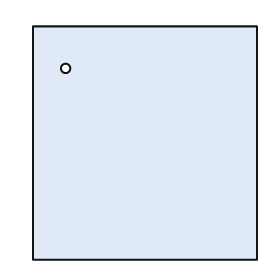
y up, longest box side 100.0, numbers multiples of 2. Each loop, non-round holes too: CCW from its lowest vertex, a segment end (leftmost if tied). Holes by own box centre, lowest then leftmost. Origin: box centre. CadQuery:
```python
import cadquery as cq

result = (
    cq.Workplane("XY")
    .moveTo(-48.0, -50.0)
    .lineTo(48.0, -50.0)
    .lineTo(48.0, 50.0)
    .lineTo(-48.0, 50.0)
    .close()
    .moveTo(-34.0, 32.0)
    .circle(2.0)
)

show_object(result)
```